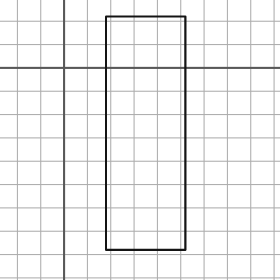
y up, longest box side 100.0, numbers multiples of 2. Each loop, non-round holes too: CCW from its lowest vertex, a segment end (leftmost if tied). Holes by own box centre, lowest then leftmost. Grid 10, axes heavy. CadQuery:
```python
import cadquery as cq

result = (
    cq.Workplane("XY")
    .moveTo(18.0, -78.0)
    .lineTo(52.0, -78.0)
    .lineTo(52.0, 22.0)
    .lineTo(18.0, 22.0)
    .close()
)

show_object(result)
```